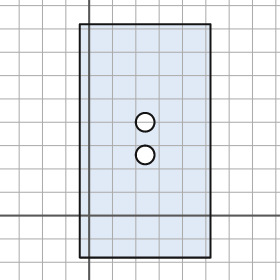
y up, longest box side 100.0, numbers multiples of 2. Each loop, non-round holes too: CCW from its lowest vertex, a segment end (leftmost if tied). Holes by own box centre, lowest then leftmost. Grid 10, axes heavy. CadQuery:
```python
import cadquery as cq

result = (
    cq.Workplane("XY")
    .moveTo(-4.0, -18.0)
    .lineTo(52.0, -18.0)
    .lineTo(52.0, 82.0)
    .lineTo(-4.0, 82.0)
    .close()
    .moveTo(24.0, 26.0)
    .circle(4.0)
    .moveTo(24.0, 40.0)
    .circle(4.0)
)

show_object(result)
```